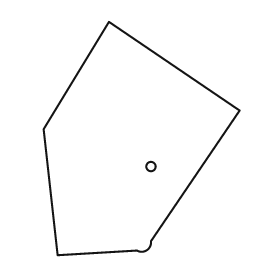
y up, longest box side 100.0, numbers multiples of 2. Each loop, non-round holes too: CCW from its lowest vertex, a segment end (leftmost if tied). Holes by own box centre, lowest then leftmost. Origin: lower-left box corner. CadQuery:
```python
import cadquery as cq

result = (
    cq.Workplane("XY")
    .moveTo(6.0, 0.0)
    .lineTo(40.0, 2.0)
    .threePointArc((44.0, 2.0), (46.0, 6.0))
    .lineTo(84.0, 62.0)
    .lineTo(28.0, 100.0)
    .lineTo(0.0, 54.0)
    .close()
    .moveTo(46.0, 38.0)
    .circle(2.0)
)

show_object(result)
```